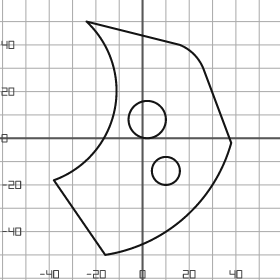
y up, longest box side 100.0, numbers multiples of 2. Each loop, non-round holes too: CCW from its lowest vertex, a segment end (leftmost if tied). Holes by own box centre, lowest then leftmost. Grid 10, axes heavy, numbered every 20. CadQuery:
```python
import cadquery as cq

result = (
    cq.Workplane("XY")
    .moveTo(-16.0, -50.0)
    .threePointArc((18.0, -34.0), (38.0, -2.0))
    .lineTo(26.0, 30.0)
    .threePointArc((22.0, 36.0), (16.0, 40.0))
    .lineTo(-24.0, 50.0)
    .threePointArc((-12.0, 12.0), (-38.0, -18.0))
    .close()
    .moveTo(10.0, -14.0)
    .circle(6.0)
    .moveTo(2.0, 8.0)
    .circle(8.0)
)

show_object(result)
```